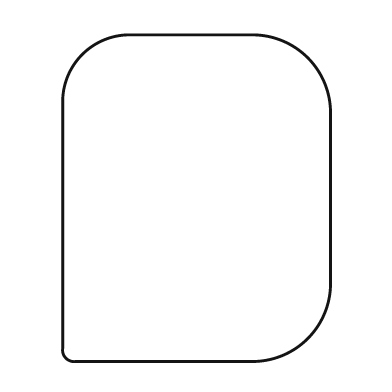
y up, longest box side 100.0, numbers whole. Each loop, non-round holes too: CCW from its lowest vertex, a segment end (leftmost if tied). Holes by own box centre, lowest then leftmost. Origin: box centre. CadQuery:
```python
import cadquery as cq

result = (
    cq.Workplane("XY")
    .moveTo(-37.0, -50.0)
    .lineTo(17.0, -50.0)
    .threePointArc((34.0, -43.0), (41.0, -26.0))
    .lineTo(41.0, 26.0)
    .threePointArc((34.0, 43.0), (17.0, 50.0))
    .lineTo(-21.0, 50.0)
    .threePointArc((-35.0, 44.0), (-41.0, 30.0))
    .lineTo(-41.0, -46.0)
    .threePointArc((-40.0, -49.0), (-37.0, -50.0))
    .close()
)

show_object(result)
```